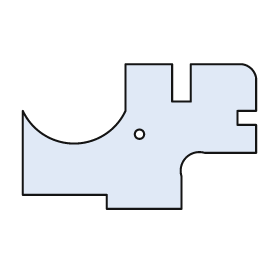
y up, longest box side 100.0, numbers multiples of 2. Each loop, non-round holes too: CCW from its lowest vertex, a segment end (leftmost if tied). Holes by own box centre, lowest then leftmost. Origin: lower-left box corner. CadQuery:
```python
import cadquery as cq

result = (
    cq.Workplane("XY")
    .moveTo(36.0, 0.0)
    .lineTo(68.0, 0.0)
    .lineTo(68.0, 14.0)
    .threePointArc((70.0, 22.0), (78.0, 24.0))
    .lineTo(100.0, 24.0)
    .lineTo(100.0, 36.0)
    .lineTo(92.0, 36.0)
    .lineTo(92.0, 42.0)
    .lineTo(100.0, 42.0)
    .lineTo(100.0, 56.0)
    .threePointArc((98.0, 60.0), (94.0, 62.0))
    .lineTo(72.0, 62.0)
    .lineTo(72.0, 46.0)
    .lineTo(64.0, 46.0)
    .lineTo(64.0, 62.0)
    .lineTo(44.0, 62.0)
    .lineTo(44.0, 42.0)
    .threePointArc((22.0, 28.0), (0.0, 42.0))
    .lineTo(0.0, 6.0)
    .lineTo(36.0, 6.0)
    .close()
    .moveTo(50.0, 32.0)
    .circle(2.0)
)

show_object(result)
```